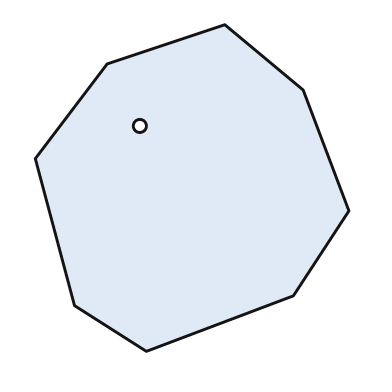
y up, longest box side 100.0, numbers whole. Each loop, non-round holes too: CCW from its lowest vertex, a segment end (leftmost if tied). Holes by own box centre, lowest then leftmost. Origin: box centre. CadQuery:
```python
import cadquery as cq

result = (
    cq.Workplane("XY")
    .moveTo(-14.0, -50.0)
    .lineTo(31.0, -33.0)
    .lineTo(48.0, -7.0)
    .lineTo(34.0, 30.0)
    .lineTo(10.0, 50.0)
    .lineTo(-26.0, 38.0)
    .lineTo(-48.0, 9.0)
    .lineTo(-36.0, -36.0)
    .close()
    .moveTo(-16.0, 19.0)
    .circle(2.0)
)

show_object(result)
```